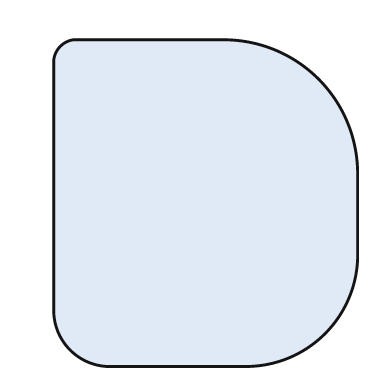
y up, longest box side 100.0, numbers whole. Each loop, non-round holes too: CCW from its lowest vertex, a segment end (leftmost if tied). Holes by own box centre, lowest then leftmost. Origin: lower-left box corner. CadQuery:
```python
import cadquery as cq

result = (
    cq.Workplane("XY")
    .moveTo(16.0, 0.0)
    .lineTo(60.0, 0.0)
    .threePointArc((83.0, 10.0), (93.0, 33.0))
    .lineTo(93.0, 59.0)
    .threePointArc((81.0, 88.0), (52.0, 100.0))
    .lineTo(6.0, 100.0)
    .threePointArc((2.0, 98.0), (0.0, 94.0))
    .lineTo(0.0, 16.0)
    .threePointArc((5.0, 5.0), (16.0, 0.0))
    .close()
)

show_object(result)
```